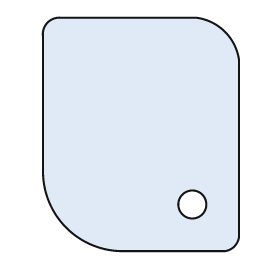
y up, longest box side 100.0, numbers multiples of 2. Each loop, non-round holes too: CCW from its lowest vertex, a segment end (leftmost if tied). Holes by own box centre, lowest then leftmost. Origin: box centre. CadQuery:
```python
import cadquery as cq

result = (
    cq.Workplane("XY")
    .moveTo(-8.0, -50.0)
    .lineTo(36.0, -50.0)
    .threePointArc((40.0, -48.0), (42.0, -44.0))
    .lineTo(42.0, 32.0)
    .threePointArc((36.0, 44.0), (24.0, 50.0))
    .lineTo(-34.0, 50.0)
    .threePointArc((-40.0, 48.0), (-42.0, 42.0))
    .lineTo(-42.0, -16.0)
    .threePointArc((-32.0, -40.0), (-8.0, -50.0))
    .close()
    .moveTo(22.0, -30.0)
    .circle(6.0)
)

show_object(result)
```